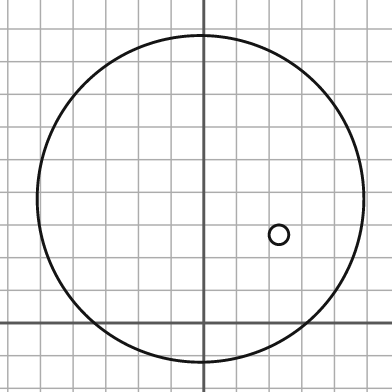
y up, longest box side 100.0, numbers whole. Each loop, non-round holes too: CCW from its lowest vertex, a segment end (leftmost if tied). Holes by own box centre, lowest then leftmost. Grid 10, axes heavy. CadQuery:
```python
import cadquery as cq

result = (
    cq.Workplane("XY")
    .moveTo(-1.0, 38.0)
    .circle(50.0)
    .moveTo(23.0, 27.0)
    .circle(3.0)
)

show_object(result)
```